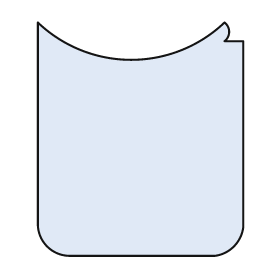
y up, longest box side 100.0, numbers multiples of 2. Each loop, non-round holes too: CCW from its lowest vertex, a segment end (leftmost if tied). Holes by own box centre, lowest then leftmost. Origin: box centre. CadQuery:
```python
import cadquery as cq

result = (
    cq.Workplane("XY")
    .moveTo(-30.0, -50.0)
    .lineTo(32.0, -50.0)
    .threePointArc((40.0, -46.0), (44.0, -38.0))
    .lineTo(44.0, 42.0)
    .lineTo(36.0, 42.0)
    .threePointArc((38.0, 46.0), (36.0, 50.0))
    .threePointArc((-4.0, 34.0), (-44.0, 50.0))
    .lineTo(-44.0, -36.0)
    .threePointArc((-40.0, -46.0), (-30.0, -50.0))
    .close()
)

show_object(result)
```